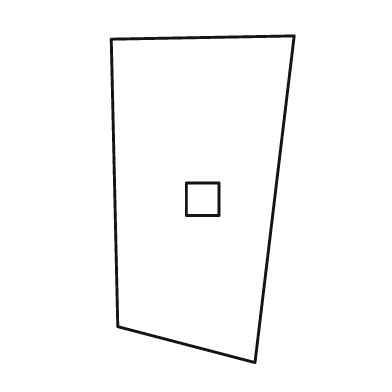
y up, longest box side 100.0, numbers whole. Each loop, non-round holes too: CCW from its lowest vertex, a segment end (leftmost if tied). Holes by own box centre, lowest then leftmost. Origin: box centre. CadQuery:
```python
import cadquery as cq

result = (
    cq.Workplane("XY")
    .moveTo(16.0, -50.0)
    .lineTo(28.0, 50.0)
    .lineTo(-28.0, 49.0)
    .lineTo(-26.0, -39.0)
    .close()
    .moveTo(-5.0, -5.0)
    .lineTo(5.0, -5.0)
    .lineTo(5.0, 5.0)
    .lineTo(-5.0, 5.0)
    .close()
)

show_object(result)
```